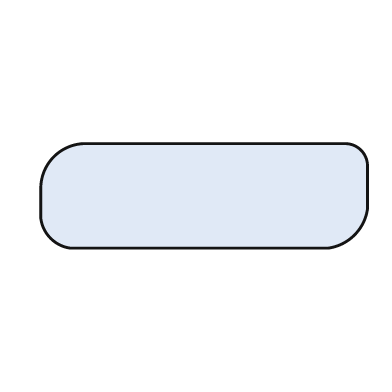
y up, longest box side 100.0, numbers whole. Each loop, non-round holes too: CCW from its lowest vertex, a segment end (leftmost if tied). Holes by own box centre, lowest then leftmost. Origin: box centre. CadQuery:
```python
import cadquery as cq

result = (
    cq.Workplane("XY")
    .moveTo(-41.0, -16.0)
    .lineTo(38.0, -16.0)
    .threePointArc((46.0, -12.0), (50.0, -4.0))
    .lineTo(50.0, 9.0)
    .threePointArc((48.0, 14.0), (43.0, 16.0))
    .lineTo(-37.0, 16.0)
    .threePointArc((-46.0, 12.0), (-50.0, 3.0))
    .lineTo(-50.0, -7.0)
    .threePointArc((-47.0, -13.0), (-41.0, -16.0))
    .close()
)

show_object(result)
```